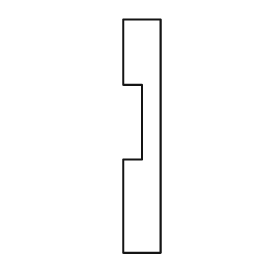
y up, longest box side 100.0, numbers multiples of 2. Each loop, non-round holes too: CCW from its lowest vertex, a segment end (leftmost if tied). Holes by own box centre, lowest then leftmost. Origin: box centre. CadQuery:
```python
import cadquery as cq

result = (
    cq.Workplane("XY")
    .moveTo(-8.0, -50.0)
    .lineTo(8.0, -50.0)
    .lineTo(8.0, 50.0)
    .lineTo(-8.0, 50.0)
    .lineTo(-8.0, 22.0)
    .lineTo(0.0, 22.0)
    .lineTo(0.0, -10.0)
    .lineTo(-8.0, -10.0)
    .close()
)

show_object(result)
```